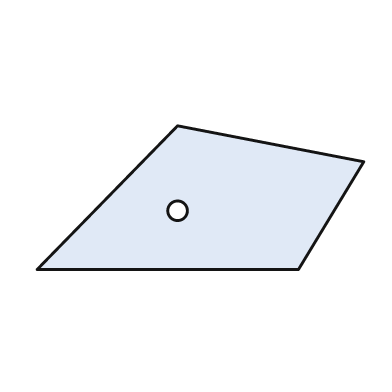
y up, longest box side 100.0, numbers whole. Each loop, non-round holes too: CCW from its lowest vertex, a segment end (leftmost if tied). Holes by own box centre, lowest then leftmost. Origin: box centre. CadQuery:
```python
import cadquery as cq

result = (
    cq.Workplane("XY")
    .moveTo(-50.0, -22.0)
    .lineTo(30.0, -22.0)
    .lineTo(50.0, 11.0)
    .lineTo(-7.0, 22.0)
    .close()
    .moveTo(-7.0, -4.0)
    .circle(3.0)
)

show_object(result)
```